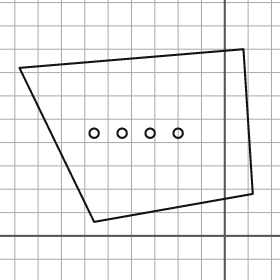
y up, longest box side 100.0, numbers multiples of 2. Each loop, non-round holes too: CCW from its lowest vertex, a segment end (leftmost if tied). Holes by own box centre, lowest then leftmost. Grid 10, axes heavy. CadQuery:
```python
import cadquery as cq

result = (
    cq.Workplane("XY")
    .moveTo(-56.0, 6.0)
    .lineTo(12.0, 18.0)
    .lineTo(8.0, 80.0)
    .lineTo(-88.0, 72.0)
    .close()
    .moveTo(-56.0, 44.0)
    .circle(2.0)
    .moveTo(-44.0, 44.0)
    .circle(2.0)
    .moveTo(-32.0, 44.0)
    .circle(2.0)
    .moveTo(-20.0, 44.0)
    .circle(2.0)
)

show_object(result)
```